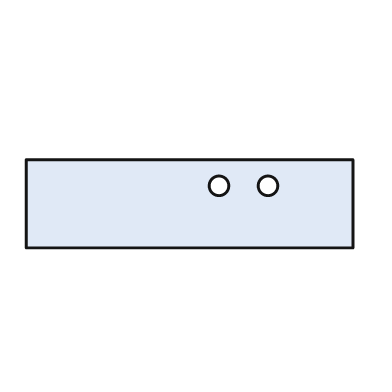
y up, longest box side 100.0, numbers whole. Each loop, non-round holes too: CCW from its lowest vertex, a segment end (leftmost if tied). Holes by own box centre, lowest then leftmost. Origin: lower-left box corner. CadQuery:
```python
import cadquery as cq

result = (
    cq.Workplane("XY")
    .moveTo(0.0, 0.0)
    .lineTo(100.0, 0.0)
    .lineTo(100.0, 27.0)
    .lineTo(0.0, 27.0)
    .close()
    .moveTo(59.0, 19.0)
    .circle(3.0)
    .moveTo(74.0, 19.0)
    .circle(3.0)
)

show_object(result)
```